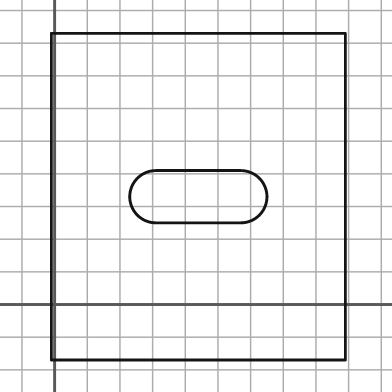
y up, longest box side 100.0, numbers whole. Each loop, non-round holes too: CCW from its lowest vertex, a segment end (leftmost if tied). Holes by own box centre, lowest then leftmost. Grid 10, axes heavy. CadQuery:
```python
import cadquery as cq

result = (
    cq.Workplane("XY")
    .moveTo(-1.0, -17.0)
    .lineTo(89.0, -17.0)
    .lineTo(89.0, 83.0)
    .lineTo(-1.0, 83.0)
    .close()
    .moveTo(31.0, 25.0)
    .lineTo(57.0, 25.0)
    .threePointArc((65.0, 33.0), (57.0, 41.0))
    .lineTo(31.0, 41.0)
    .threePointArc((23.0, 33.0), (31.0, 25.0))
    .close()
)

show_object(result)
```